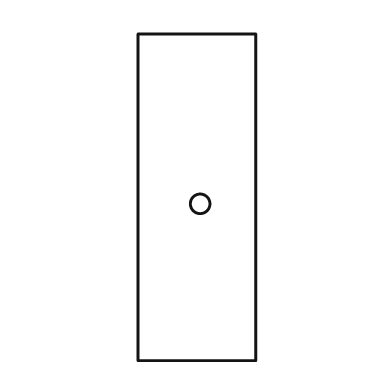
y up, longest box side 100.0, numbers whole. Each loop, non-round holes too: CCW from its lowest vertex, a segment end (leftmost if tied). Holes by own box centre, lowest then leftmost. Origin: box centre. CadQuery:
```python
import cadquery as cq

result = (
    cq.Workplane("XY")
    .moveTo(-18.0, -50.0)
    .lineTo(18.0, -50.0)
    .lineTo(18.0, 50.0)
    .lineTo(-18.0, 50.0)
    .close()
    .moveTo(1.0, -2.0)
    .circle(3.0)
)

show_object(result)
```